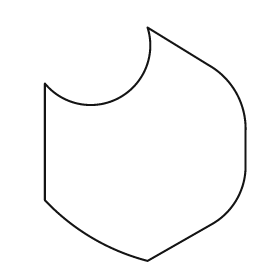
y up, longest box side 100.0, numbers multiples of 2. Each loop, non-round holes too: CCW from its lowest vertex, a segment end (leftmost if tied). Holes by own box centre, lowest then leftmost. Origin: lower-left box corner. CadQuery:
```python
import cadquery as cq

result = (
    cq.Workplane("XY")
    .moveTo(44.0, 0.0)
    .lineTo(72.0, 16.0)
    .threePointArc((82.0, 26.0), (86.0, 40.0))
    .lineTo(86.0, 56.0)
    .threePointArc((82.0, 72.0), (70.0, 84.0))
    .lineTo(44.0, 100.0)
    .threePointArc((32.0, 70.0), (0.0, 76.0))
    .lineTo(0.0, 26.0)
    .threePointArc((20.0, 10.0), (44.0, 0.0))
    .close()
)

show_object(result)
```